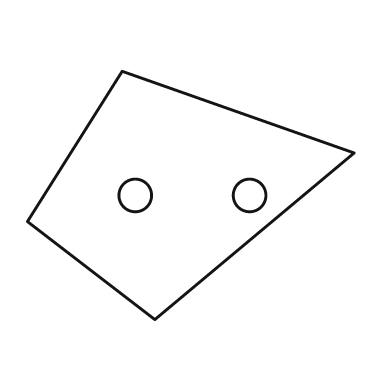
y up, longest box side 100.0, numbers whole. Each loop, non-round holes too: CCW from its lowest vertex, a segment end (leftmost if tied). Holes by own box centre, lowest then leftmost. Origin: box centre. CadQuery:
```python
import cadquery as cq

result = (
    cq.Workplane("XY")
    .moveTo(-11.0, -38.0)
    .lineTo(50.0, 13.0)
    .lineTo(-21.0, 38.0)
    .lineTo(-50.0, -8.0)
    .close()
    .moveTo(-17.0, 0.0)
    .circle(5.0)
    .moveTo(18.0, 0.0)
    .circle(5.0)
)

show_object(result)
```